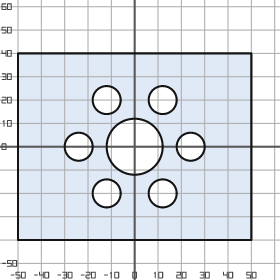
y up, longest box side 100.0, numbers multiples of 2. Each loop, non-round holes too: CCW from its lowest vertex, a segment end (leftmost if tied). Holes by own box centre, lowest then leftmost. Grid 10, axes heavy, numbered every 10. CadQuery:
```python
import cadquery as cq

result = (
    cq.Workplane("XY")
    .moveTo(-50.0, -40.0)
    .lineTo(50.0, -40.0)
    .lineTo(50.0, 40.0)
    .lineTo(-50.0, 40.0)
    .close()
    .moveTo(-12.0, -20.0)
    .circle(6.0)
    .moveTo(12.0, -20.0)
    .circle(6.0)
    .moveTo(-24.0, 0.0)
    .circle(6.0)
    .moveTo(0.0, 0.0)
    .circle(12.0)
    .moveTo(24.0, 0.0)
    .circle(6.0)
    .moveTo(-12.0, 20.0)
    .circle(6.0)
    .moveTo(12.0, 20.0)
    .circle(6.0)
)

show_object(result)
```